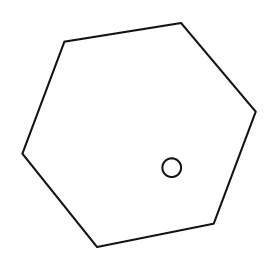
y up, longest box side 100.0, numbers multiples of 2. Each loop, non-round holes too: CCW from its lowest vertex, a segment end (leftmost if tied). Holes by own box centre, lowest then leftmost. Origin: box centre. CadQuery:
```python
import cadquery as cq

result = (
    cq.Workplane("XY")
    .moveTo(-18.0, -48.0)
    .lineTo(32.0, -38.0)
    .lineTo(50.0, 10.0)
    .lineTo(18.0, 48.0)
    .lineTo(-32.0, 40.0)
    .lineTo(-50.0, -8.0)
    .close()
    .moveTo(14.0, -14.0)
    .circle(4.0)
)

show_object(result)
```